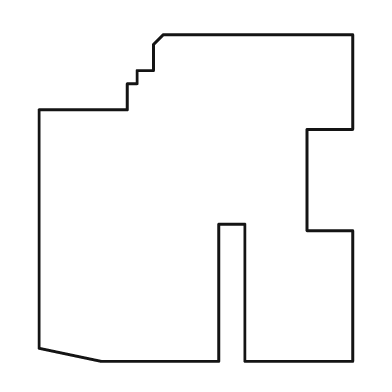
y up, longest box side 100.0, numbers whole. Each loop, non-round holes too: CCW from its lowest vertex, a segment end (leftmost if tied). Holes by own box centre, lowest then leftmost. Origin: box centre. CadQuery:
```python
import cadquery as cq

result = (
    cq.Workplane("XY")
    .moveTo(-29.0, -50.0)
    .lineTo(7.0, -50.0)
    .lineTo(7.0, -8.0)
    .lineTo(15.0, -8.0)
    .lineTo(15.0, -50.0)
    .lineTo(48.0, -50.0)
    .lineTo(48.0, -10.0)
    .lineTo(34.0, -10.0)
    .lineTo(34.0, 21.0)
    .lineTo(48.0, 21.0)
    .lineTo(48.0, 50.0)
    .lineTo(-10.0, 50.0)
    .lineTo(-13.0, 47.0)
    .lineTo(-13.0, 39.0)
    .lineTo(-18.0, 39.0)
    .lineTo(-18.0, 35.0)
    .lineTo(-21.0, 35.0)
    .lineTo(-21.0, 27.0)
    .lineTo(-48.0, 27.0)
    .lineTo(-48.0, -46.0)
    .close()
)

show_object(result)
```